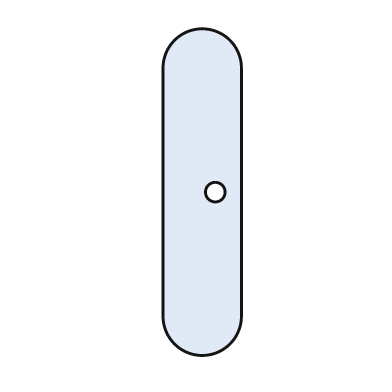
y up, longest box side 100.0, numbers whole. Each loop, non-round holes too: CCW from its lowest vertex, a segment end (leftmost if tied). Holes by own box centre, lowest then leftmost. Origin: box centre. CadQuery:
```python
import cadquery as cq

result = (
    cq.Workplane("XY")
    .moveTo(-12.0, -38.0)
    .threePointArc((0.0, -50.0), (12.0, -38.0))
    .lineTo(12.0, 38.0)
    .threePointArc((0.0, 50.0), (-12.0, 38.0))
    .close()
    .moveTo(4.0, 0.0)
    .circle(3.0)
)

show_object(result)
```